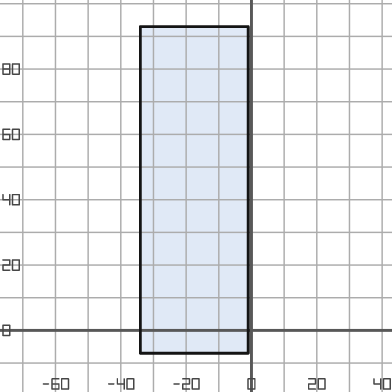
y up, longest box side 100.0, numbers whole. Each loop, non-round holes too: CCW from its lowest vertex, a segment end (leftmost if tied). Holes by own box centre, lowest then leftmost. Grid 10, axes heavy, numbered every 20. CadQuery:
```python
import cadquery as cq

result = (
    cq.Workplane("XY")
    .moveTo(-34.0, -7.0)
    .lineTo(-1.0, -7.0)
    .lineTo(-1.0, 93.0)
    .lineTo(-34.0, 93.0)
    .close()
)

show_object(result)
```